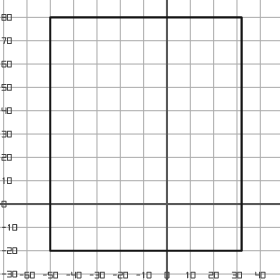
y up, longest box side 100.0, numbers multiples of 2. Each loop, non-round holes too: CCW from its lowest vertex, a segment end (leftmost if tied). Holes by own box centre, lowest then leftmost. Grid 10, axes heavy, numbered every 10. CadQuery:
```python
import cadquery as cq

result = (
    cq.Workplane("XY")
    .moveTo(-50.0, -20.0)
    .lineTo(32.0, -20.0)
    .lineTo(32.0, 80.0)
    .lineTo(-50.0, 80.0)
    .close()
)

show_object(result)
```